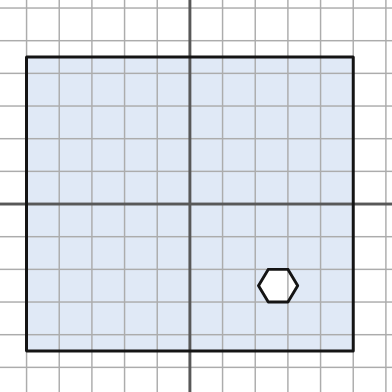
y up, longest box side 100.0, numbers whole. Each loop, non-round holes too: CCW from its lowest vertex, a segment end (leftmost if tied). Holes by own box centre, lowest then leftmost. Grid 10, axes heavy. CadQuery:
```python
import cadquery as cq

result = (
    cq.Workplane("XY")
    .moveTo(-50.0, -45.0)
    .lineTo(50.0, -45.0)
    .lineTo(50.0, 45.0)
    .lineTo(-50.0, 45.0)
    .close()
    .moveTo(24.0, -30.0)
    .lineTo(30.0, -30.0)
    .lineTo(33.0, -25.0)
    .lineTo(30.0, -20.0)
    .lineTo(24.0, -20.0)
    .lineTo(21.0, -25.0)
    .close()
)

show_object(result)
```